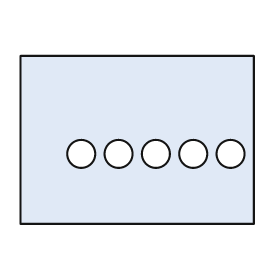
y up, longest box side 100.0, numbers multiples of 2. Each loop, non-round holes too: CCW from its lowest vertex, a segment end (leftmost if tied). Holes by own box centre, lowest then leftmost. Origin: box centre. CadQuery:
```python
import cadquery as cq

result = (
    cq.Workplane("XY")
    .moveTo(-50.0, -36.0)
    .lineTo(50.0, -36.0)
    .lineTo(50.0, 36.0)
    .lineTo(-50.0, 36.0)
    .close()
    .moveTo(-24.0, -6.0)
    .circle(6.0)
    .moveTo(-8.0, -6.0)
    .circle(6.0)
    .moveTo(8.0, -6.0)
    .circle(6.0)
    .moveTo(24.0, -6.0)
    .circle(6.0)
    .moveTo(40.0, -6.0)
    .circle(6.0)
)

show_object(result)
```